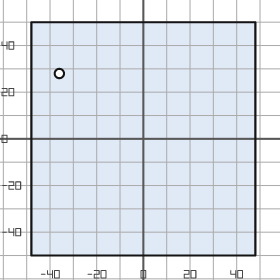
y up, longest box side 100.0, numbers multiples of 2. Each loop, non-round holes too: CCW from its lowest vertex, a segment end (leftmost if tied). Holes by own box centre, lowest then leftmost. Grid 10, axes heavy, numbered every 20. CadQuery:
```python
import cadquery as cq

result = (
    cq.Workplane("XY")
    .moveTo(-48.0, -50.0)
    .lineTo(48.0, -50.0)
    .lineTo(48.0, 50.0)
    .lineTo(-48.0, 50.0)
    .close()
    .moveTo(-36.0, 28.0)
    .circle(2.0)
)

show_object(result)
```